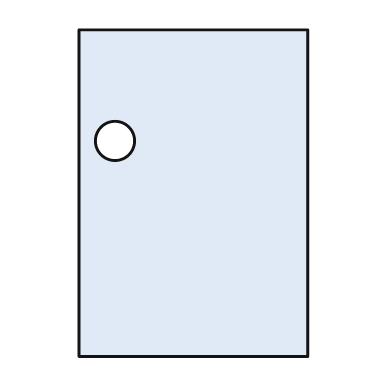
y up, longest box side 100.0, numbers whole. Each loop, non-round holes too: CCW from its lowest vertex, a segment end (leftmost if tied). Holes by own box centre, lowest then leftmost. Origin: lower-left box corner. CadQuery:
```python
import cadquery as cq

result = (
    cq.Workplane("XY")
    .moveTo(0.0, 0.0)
    .lineTo(70.0, 0.0)
    .lineTo(70.0, 100.0)
    .lineTo(0.0, 100.0)
    .close()
    .moveTo(11.0, 66.0)
    .circle(6.0)
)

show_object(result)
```